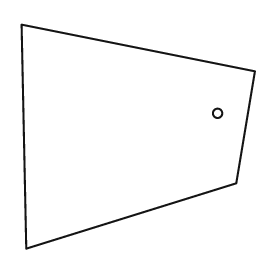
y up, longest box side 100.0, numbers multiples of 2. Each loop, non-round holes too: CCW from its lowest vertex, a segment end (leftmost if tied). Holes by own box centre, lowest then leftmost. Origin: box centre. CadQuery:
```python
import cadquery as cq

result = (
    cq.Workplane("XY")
    .moveTo(-48.0, -48.0)
    .lineTo(42.0, -20.0)
    .lineTo(50.0, 28.0)
    .lineTo(-50.0, 48.0)
    .close()
    .moveTo(34.0, 10.0)
    .circle(2.0)
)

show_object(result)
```